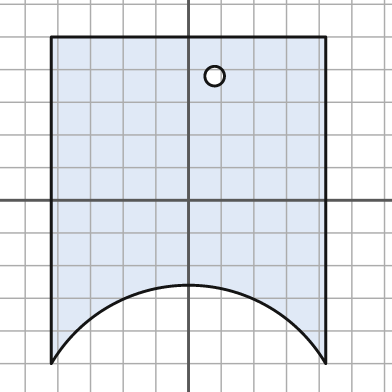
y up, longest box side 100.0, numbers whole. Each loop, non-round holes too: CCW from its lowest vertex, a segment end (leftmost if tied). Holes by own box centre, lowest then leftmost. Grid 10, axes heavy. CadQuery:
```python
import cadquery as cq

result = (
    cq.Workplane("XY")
    .moveTo(-42.0, -50.0)
    .threePointArc((0.0, -26.0), (42.0, -50.0))
    .lineTo(42.0, 50.0)
    .lineTo(-42.0, 50.0)
    .close()
    .moveTo(8.0, 38.0)
    .circle(3.0)
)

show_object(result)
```